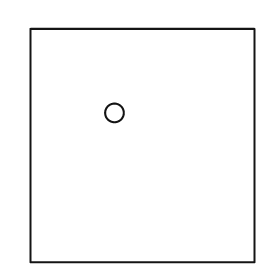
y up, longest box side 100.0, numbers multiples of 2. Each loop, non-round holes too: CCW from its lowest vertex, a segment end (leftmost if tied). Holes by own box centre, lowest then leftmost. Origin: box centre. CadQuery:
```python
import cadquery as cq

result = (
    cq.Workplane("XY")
    .moveTo(-48.0, -50.0)
    .lineTo(48.0, -50.0)
    .lineTo(48.0, 50.0)
    .lineTo(-48.0, 50.0)
    .close()
    .moveTo(-12.0, 14.0)
    .circle(4.0)
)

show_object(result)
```